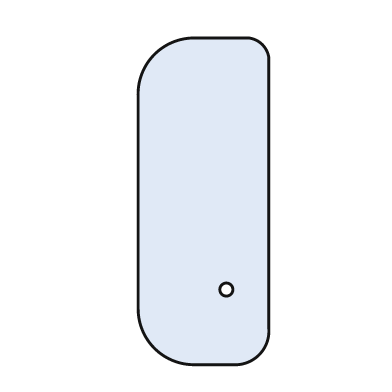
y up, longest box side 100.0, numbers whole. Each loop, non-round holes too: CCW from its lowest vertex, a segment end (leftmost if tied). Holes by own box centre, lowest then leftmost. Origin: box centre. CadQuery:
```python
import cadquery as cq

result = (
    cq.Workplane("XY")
    .moveTo(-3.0, -50.0)
    .lineTo(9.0, -50.0)
    .threePointArc((17.0, -47.0), (20.0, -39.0))
    .lineTo(20.0, 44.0)
    .threePointArc((18.0, 48.0), (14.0, 50.0))
    .lineTo(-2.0, 50.0)
    .threePointArc((-15.0, 45.0), (-20.0, 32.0))
    .lineTo(-20.0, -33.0)
    .threePointArc((-15.0, -45.0), (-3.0, -50.0))
    .close()
    .moveTo(7.0, -27.0)
    .circle(2.0)
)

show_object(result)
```